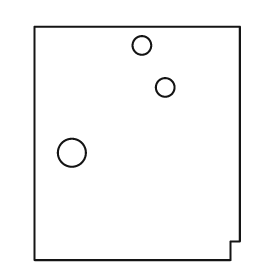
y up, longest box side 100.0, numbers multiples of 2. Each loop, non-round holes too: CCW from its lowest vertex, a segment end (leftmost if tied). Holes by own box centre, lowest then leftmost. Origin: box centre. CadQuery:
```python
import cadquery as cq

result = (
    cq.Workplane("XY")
    .moveTo(-44.0, -50.0)
    .lineTo(40.0, -50.0)
    .lineTo(40.0, -42.0)
    .lineTo(44.0, -42.0)
    .lineTo(44.0, 50.0)
    .lineTo(-44.0, 50.0)
    .close()
    .moveTo(-28.0, -4.0)
    .circle(6.0)
    .moveTo(12.0, 24.0)
    .circle(4.0)
    .moveTo(2.0, 42.0)
    .circle(4.0)
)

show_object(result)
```